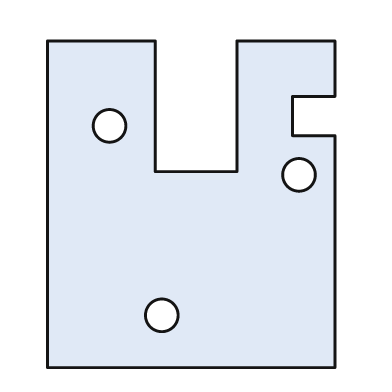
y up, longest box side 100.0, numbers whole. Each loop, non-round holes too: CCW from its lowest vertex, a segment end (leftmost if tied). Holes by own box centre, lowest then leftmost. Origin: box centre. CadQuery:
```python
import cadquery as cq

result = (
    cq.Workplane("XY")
    .moveTo(-44.0, -50.0)
    .lineTo(44.0, -50.0)
    .lineTo(44.0, 21.0)
    .lineTo(31.0, 21.0)
    .lineTo(31.0, 33.0)
    .lineTo(44.0, 33.0)
    .lineTo(44.0, 50.0)
    .lineTo(14.0, 50.0)
    .lineTo(14.0, 10.0)
    .lineTo(-11.0, 10.0)
    .lineTo(-11.0, 50.0)
    .lineTo(-44.0, 50.0)
    .close()
    .moveTo(-9.0, -34.0)
    .circle(5.0)
    .moveTo(33.0, 9.0)
    .circle(5.0)
    .moveTo(-25.0, 24.0)
    .circle(5.0)
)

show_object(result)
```